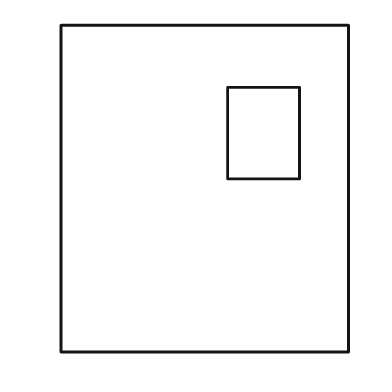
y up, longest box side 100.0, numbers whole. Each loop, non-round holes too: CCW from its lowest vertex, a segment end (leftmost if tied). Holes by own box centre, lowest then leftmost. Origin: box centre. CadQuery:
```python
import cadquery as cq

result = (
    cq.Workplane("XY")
    .moveTo(-44.0, -50.0)
    .lineTo(44.0, -50.0)
    .lineTo(44.0, 50.0)
    .lineTo(-44.0, 50.0)
    .close()
    .moveTo(7.0, 3.0)
    .lineTo(29.0, 3.0)
    .lineTo(29.0, 31.0)
    .lineTo(7.0, 31.0)
    .close()
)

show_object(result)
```